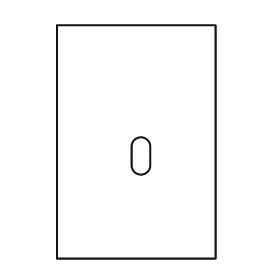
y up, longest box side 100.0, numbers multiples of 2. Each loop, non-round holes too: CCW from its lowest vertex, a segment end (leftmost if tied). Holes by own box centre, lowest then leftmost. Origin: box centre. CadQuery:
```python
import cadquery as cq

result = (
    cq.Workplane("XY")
    .moveTo(-34.0, -50.0)
    .lineTo(34.0, -50.0)
    .lineTo(34.0, 50.0)
    .lineTo(-34.0, 50.0)
    .close()
    .moveTo(-2.0, -10.0)
    .threePointArc((2.0, -14.0), (6.0, -10.0))
    .lineTo(6.0, -2.0)
    .threePointArc((2.0, 2.0), (-2.0, -2.0))
    .close()
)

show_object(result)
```